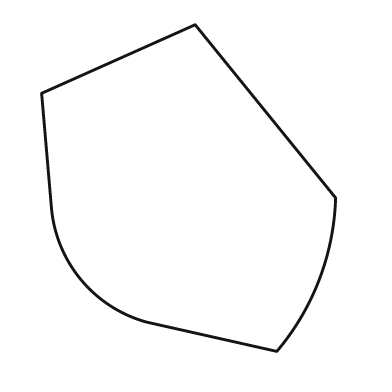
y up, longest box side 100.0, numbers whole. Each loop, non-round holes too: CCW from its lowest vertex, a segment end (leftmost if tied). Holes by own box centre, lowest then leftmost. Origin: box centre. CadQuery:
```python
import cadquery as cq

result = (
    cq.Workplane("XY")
    .moveTo(27.0, -50.0)
    .threePointArc((40.0, -28.0), (45.0, -3.0))
    .lineTo(2.0, 50.0)
    .lineTo(-45.0, 29.0)
    .lineTo(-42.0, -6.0)
    .threePointArc((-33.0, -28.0), (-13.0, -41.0))
    .close()
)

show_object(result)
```